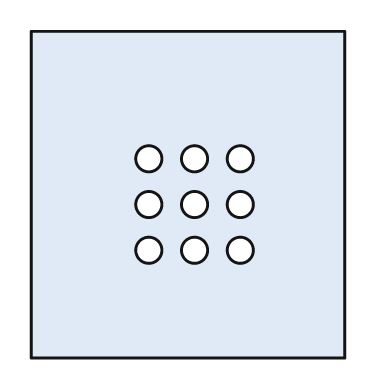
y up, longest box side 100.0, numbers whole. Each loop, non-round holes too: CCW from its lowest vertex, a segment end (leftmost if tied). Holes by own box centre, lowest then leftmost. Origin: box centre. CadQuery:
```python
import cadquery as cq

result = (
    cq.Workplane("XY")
    .moveTo(-48.0, -50.0)
    .lineTo(48.0, -50.0)
    .lineTo(48.0, 50.0)
    .lineTo(-48.0, 50.0)
    .close()
    .moveTo(-12.0, -17.0)
    .circle(4.0)
    .moveTo(2.0, -17.0)
    .circle(4.0)
    .moveTo(16.0, -17.0)
    .circle(4.0)
    .moveTo(-12.0, -3.0)
    .circle(4.0)
    .moveTo(2.0, -3.0)
    .circle(4.0)
    .moveTo(16.0, -3.0)
    .circle(4.0)
    .moveTo(-12.0, 11.0)
    .circle(4.0)
    .moveTo(2.0, 11.0)
    .circle(4.0)
    .moveTo(16.0, 11.0)
    .circle(4.0)
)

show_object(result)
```